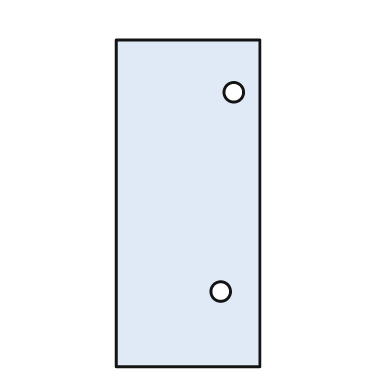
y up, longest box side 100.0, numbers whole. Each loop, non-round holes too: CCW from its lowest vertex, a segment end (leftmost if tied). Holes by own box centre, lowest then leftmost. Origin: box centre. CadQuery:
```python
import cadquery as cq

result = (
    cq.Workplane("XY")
    .moveTo(-22.0, -50.0)
    .lineTo(22.0, -50.0)
    .lineTo(22.0, 50.0)
    .lineTo(-22.0, 50.0)
    .close()
    .moveTo(10.0, -27.0)
    .circle(3.0)
    .moveTo(14.0, 34.0)
    .circle(3.0)
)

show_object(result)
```